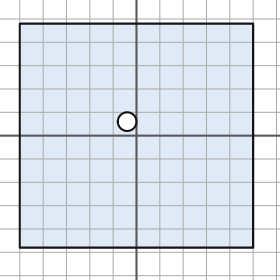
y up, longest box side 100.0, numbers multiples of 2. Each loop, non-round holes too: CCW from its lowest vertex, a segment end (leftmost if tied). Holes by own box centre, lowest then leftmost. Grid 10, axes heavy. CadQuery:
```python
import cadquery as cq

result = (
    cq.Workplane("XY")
    .moveTo(-50.0, -48.0)
    .lineTo(50.0, -48.0)
    .lineTo(50.0, 48.0)
    .lineTo(-50.0, 48.0)
    .close()
    .moveTo(-4.0, 6.0)
    .circle(4.0)
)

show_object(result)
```